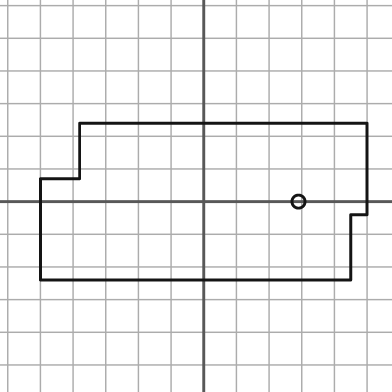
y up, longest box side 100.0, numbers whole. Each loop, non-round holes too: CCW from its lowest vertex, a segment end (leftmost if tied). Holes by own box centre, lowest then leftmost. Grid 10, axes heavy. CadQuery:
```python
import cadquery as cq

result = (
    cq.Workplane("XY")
    .moveTo(-50.0, -24.0)
    .lineTo(45.0, -24.0)
    .lineTo(45.0, -4.0)
    .lineTo(50.0, -4.0)
    .lineTo(50.0, 24.0)
    .lineTo(-38.0, 24.0)
    .lineTo(-38.0, 7.0)
    .lineTo(-50.0, 7.0)
    .close()
    .moveTo(29.0, 0.0)
    .circle(2.0)
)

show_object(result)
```